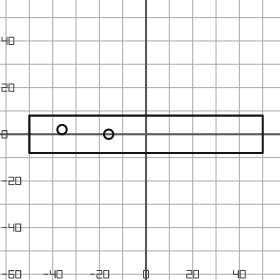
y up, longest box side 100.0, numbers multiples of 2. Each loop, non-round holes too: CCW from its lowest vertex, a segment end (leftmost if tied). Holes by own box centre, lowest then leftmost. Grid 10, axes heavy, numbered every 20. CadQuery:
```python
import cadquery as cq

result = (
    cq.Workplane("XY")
    .moveTo(-50.0, -8.0)
    .lineTo(50.0, -8.0)
    .lineTo(50.0, 8.0)
    .lineTo(-50.0, 8.0)
    .close()
    .moveTo(-16.0, 0.0)
    .circle(2.0)
    .moveTo(-36.0, 2.0)
    .circle(2.0)
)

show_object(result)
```